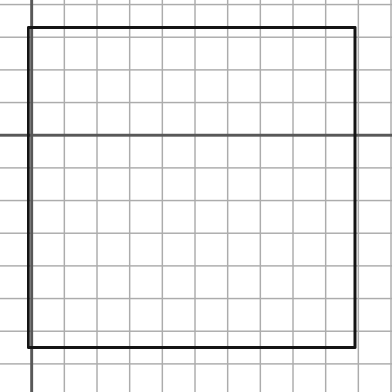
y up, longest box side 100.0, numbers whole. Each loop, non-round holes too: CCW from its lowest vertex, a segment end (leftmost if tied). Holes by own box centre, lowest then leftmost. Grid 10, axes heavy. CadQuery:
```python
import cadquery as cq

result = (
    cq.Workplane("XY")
    .moveTo(-1.0, -65.0)
    .lineTo(99.0, -65.0)
    .lineTo(99.0, 33.0)
    .lineTo(-1.0, 33.0)
    .close()
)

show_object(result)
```